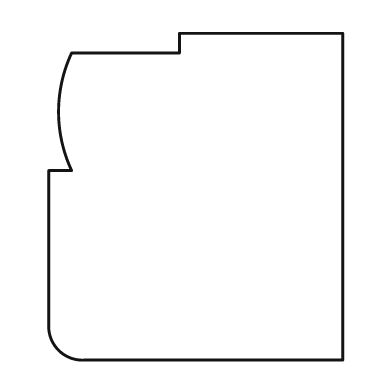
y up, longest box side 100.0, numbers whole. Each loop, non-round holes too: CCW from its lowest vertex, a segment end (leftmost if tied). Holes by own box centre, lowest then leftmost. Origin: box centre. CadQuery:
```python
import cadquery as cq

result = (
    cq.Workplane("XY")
    .moveTo(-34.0, -50.0)
    .lineTo(45.0, -50.0)
    .lineTo(45.0, 50.0)
    .lineTo(-5.0, 50.0)
    .lineTo(-5.0, 44.0)
    .lineTo(-38.0, 44.0)
    .threePointArc((-42.0, 26.0), (-38.0, 8.0))
    .lineTo(-45.0, 8.0)
    .lineTo(-45.0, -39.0)
    .threePointArc((-42.0, -47.0), (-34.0, -50.0))
    .close()
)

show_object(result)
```